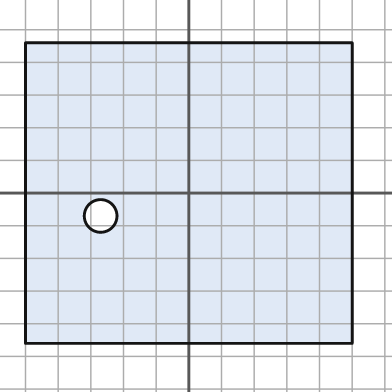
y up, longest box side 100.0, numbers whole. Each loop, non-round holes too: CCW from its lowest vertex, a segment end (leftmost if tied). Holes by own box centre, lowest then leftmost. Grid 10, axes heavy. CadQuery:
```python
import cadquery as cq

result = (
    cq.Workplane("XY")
    .moveTo(-50.0, -46.0)
    .lineTo(50.0, -46.0)
    .lineTo(50.0, 46.0)
    .lineTo(-50.0, 46.0)
    .close()
    .moveTo(-27.0, -7.0)
    .circle(5.0)
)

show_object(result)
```